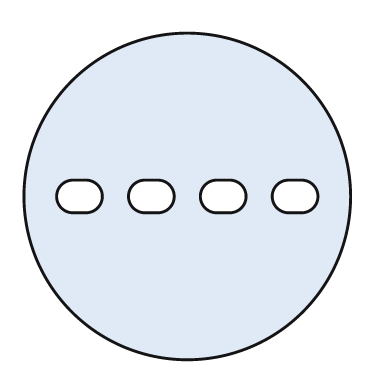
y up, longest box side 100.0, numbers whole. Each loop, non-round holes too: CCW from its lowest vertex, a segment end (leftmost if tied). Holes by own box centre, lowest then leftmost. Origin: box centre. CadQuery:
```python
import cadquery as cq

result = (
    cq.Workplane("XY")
    .moveTo(0.0, 0.0)
    .circle(50.0)
    .moveTo(-35.0, -5.0)
    .lineTo(-31.0, -5.0)
    .threePointArc((-26.0, 0.0), (-31.0, 5.0))
    .lineTo(-35.0, 5.0)
    .threePointArc((-40.0, 0.0), (-35.0, -5.0))
    .close()
    .moveTo(-13.0, -5.0)
    .lineTo(-9.0, -5.0)
    .threePointArc((-4.0, 0.0), (-9.0, 5.0))
    .lineTo(-13.0, 5.0)
    .threePointArc((-18.0, 0.0), (-13.0, -5.0))
    .close()
    .moveTo(9.0, -5.0)
    .lineTo(13.0, -5.0)
    .threePointArc((18.0, 0.0), (13.0, 5.0))
    .lineTo(9.0, 5.0)
    .threePointArc((4.0, 0.0), (9.0, -5.0))
    .close()
    .moveTo(31.0, -5.0)
    .lineTo(35.0, -5.0)
    .threePointArc((40.0, 0.0), (35.0, 5.0))
    .lineTo(31.0, 5.0)
    .threePointArc((26.0, 0.0), (31.0, -5.0))
    .close()
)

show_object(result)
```